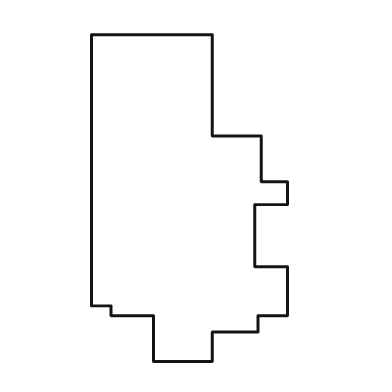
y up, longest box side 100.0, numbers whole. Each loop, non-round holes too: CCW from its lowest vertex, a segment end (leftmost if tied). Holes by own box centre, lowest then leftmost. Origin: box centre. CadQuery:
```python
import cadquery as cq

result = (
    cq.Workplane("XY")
    .moveTo(-11.0, -50.0)
    .lineTo(7.0, -50.0)
    .lineTo(7.0, -41.0)
    .lineTo(21.0, -41.0)
    .lineTo(21.0, -36.0)
    .lineTo(30.0, -36.0)
    .lineTo(30.0, -21.0)
    .lineTo(20.0, -21.0)
    .lineTo(20.0, -2.0)
    .lineTo(30.0, -2.0)
    .lineTo(30.0, 5.0)
    .lineTo(22.0, 5.0)
    .lineTo(22.0, 19.0)
    .lineTo(7.0, 19.0)
    .lineTo(7.0, 50.0)
    .lineTo(-30.0, 50.0)
    .lineTo(-30.0, -33.0)
    .lineTo(-24.0, -33.0)
    .lineTo(-24.0, -36.0)
    .lineTo(-11.0, -36.0)
    .close()
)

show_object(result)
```